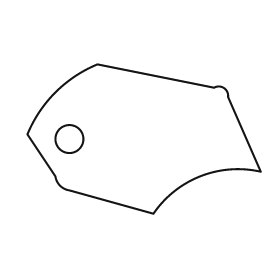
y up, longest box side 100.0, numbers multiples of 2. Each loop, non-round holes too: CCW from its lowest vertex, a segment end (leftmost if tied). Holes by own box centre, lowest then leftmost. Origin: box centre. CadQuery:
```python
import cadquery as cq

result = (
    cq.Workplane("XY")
    .moveTo(4.0, -32.0)
    .threePointArc((24.0, -16.0), (50.0, -14.0))
    .lineTo(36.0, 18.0)
    .threePointArc((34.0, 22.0), (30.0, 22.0))
    .lineTo(-20.0, 32.0)
    .threePointArc((-38.0, 20.0), (-50.0, 2.0))
    .lineTo(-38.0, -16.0)
    .threePointArc((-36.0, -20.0), (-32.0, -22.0))
    .close()
    .moveTo(-32.0, 0.0)
    .circle(6.0)
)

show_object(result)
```